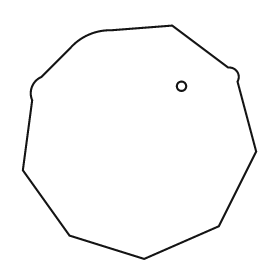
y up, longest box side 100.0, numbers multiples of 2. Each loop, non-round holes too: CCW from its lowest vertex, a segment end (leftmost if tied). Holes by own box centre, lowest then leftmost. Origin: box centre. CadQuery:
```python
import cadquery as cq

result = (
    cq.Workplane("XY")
    .moveTo(2.0, -50.0)
    .lineTo(34.0, -36.0)
    .lineTo(50.0, -4.0)
    .lineTo(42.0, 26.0)
    .threePointArc((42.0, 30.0), (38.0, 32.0))
    .lineTo(14.0, 50.0)
    .lineTo(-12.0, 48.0)
    .threePointArc((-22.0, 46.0), (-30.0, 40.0))
    .lineTo(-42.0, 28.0)
    .threePointArc((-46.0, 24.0), (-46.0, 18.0))
    .lineTo(-50.0, -12.0)
    .lineTo(-30.0, -40.0)
    .close()
    .moveTo(18.0, 24.0)
    .circle(2.0)
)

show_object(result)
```